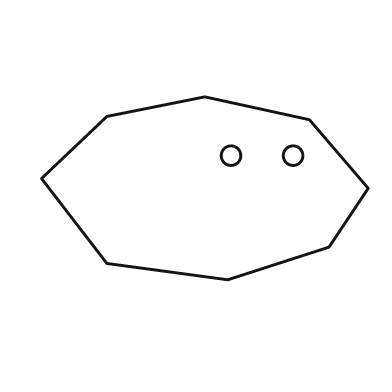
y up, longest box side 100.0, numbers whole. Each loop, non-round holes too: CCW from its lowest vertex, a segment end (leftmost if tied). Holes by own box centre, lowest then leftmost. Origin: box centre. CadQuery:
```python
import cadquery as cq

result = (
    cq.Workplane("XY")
    .moveTo(7.0, -28.0)
    .lineTo(38.0, -18.0)
    .lineTo(50.0, 0.0)
    .lineTo(32.0, 21.0)
    .lineTo(0.0, 28.0)
    .lineTo(-30.0, 22.0)
    .lineTo(-50.0, 3.0)
    .lineTo(-30.0, -23.0)
    .close()
    .moveTo(8.0, 10.0)
    .circle(3.0)
    .moveTo(27.0, 10.0)
    .circle(3.0)
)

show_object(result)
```